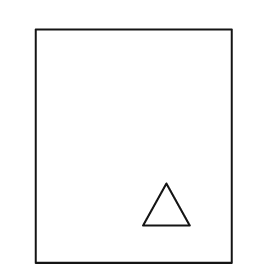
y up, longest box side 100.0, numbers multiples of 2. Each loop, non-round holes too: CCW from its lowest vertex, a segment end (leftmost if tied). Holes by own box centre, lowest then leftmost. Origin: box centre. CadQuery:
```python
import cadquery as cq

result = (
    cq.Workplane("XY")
    .moveTo(-42.0, -50.0)
    .lineTo(42.0, -50.0)
    .lineTo(42.0, 50.0)
    .lineTo(-42.0, 50.0)
    .close()
    .moveTo(4.0, -34.0)
    .lineTo(24.0, -34.0)
    .lineTo(14.0, -16.0)
    .close()
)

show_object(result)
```